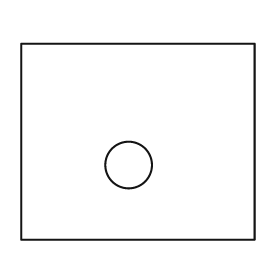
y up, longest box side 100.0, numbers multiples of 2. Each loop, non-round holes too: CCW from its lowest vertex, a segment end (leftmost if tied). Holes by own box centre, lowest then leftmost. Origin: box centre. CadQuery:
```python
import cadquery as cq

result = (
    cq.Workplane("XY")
    .moveTo(-50.0, -42.0)
    .lineTo(50.0, -42.0)
    .lineTo(50.0, 42.0)
    .lineTo(-50.0, 42.0)
    .close()
    .moveTo(-4.0, -10.0)
    .circle(10.0)
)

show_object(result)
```